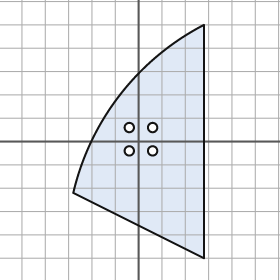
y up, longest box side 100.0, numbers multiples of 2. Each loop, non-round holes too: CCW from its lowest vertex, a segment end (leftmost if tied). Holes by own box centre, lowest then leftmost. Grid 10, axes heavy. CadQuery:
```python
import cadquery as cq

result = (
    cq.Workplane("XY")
    .moveTo(28.0, -50.0)
    .lineTo(28.0, 50.0)
    .threePointArc((-8.0, 20.0), (-28.0, -22.0))
    .close()
    .moveTo(-4.0, -4.0)
    .circle(2.0)
    .moveTo(6.0, -4.0)
    .circle(2.0)
    .moveTo(-4.0, 6.0)
    .circle(2.0)
    .moveTo(6.0, 6.0)
    .circle(2.0)
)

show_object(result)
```